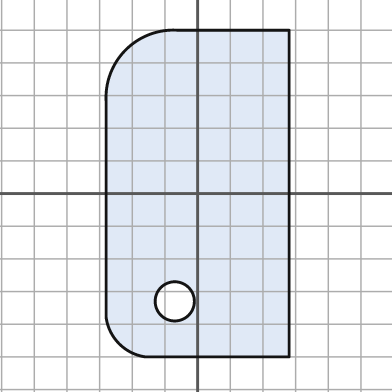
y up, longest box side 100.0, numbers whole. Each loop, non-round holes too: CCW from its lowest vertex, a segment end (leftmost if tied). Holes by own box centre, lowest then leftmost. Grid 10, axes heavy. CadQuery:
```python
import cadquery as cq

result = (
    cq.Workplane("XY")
    .moveTo(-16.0, -50.0)
    .lineTo(28.0, -50.0)
    .lineTo(28.0, 50.0)
    .lineTo(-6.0, 50.0)
    .threePointArc((-22.0, 44.0), (-28.0, 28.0))
    .lineTo(-28.0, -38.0)
    .threePointArc((-24.0, -46.0), (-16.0, -50.0))
    .close()
    .moveTo(-7.0, -33.0)
    .circle(6.0)
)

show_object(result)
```